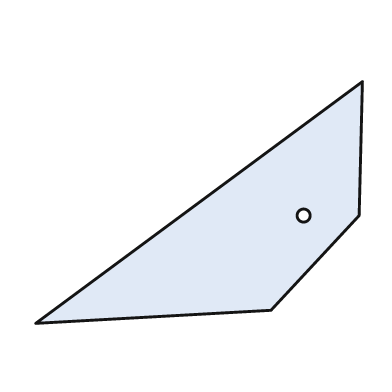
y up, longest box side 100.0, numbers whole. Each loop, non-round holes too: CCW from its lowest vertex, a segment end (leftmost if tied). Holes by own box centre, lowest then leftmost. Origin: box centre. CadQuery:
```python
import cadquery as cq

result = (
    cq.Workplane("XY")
    .moveTo(-50.0, -37.0)
    .lineTo(22.0, -33.0)
    .lineTo(49.0, -4.0)
    .lineTo(50.0, 37.0)
    .close()
    .moveTo(32.0, -4.0)
    .circle(2.0)
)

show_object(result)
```